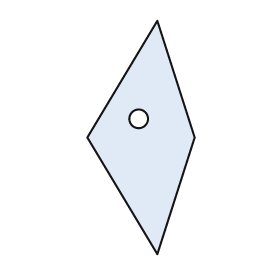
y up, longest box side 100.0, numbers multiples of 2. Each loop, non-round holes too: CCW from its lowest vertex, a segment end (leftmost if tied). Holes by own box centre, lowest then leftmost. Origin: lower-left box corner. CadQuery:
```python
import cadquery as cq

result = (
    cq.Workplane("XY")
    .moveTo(30.0, 0.0)
    .lineTo(46.0, 50.0)
    .lineTo(30.0, 100.0)
    .lineTo(0.0, 50.0)
    .close()
    .moveTo(22.0, 58.0)
    .circle(4.0)
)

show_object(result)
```